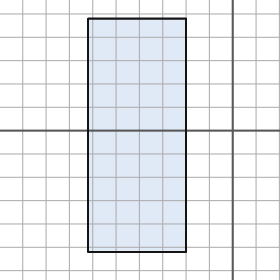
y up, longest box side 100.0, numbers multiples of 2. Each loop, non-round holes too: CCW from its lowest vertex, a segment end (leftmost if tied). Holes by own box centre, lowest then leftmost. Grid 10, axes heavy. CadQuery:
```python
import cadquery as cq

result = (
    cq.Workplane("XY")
    .moveTo(-62.0, -52.0)
    .lineTo(-20.0, -52.0)
    .lineTo(-20.0, 48.0)
    .lineTo(-62.0, 48.0)
    .close()
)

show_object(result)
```